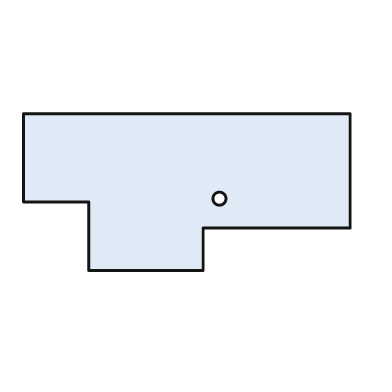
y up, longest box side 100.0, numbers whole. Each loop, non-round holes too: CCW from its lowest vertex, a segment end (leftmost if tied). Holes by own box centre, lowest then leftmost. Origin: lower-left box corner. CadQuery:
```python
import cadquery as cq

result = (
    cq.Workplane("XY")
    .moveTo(20.0, 0.0)
    .lineTo(55.0, 0.0)
    .lineTo(55.0, 13.0)
    .lineTo(100.0, 13.0)
    .lineTo(100.0, 48.0)
    .lineTo(0.0, 48.0)
    .lineTo(0.0, 21.0)
    .lineTo(20.0, 21.0)
    .close()
    .moveTo(60.0, 22.0)
    .circle(2.0)
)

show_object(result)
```